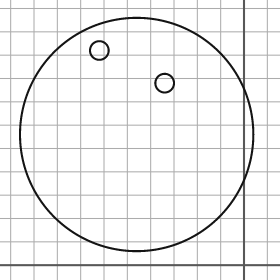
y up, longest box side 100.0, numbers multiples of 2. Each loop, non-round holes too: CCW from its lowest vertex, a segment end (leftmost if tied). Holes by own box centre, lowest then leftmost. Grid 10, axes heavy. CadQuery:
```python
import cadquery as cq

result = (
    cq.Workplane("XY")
    .moveTo(-46.0, 56.0)
    .circle(50.0)
    .moveTo(-34.0, 78.0)
    .circle(4.0)
    .moveTo(-62.0, 92.0)
    .circle(4.0)
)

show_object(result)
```